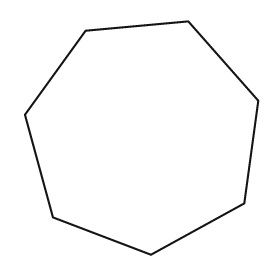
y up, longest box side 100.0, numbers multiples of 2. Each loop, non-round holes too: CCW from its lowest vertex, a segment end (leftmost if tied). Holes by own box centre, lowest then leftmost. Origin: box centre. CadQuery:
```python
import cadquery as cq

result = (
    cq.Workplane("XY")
    .moveTo(4.0, -50.0)
    .lineTo(44.0, -28.0)
    .lineTo(50.0, 16.0)
    .lineTo(20.0, 50.0)
    .lineTo(-24.0, 46.0)
    .lineTo(-50.0, 10.0)
    .lineTo(-38.0, -34.0)
    .close()
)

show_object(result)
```